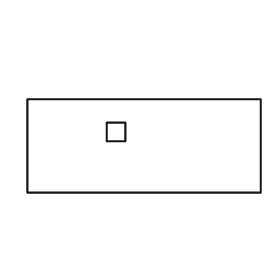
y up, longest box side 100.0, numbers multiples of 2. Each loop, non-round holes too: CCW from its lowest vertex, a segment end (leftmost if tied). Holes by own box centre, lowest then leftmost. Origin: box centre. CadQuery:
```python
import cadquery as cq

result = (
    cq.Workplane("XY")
    .moveTo(-50.0, -20.0)
    .lineTo(50.0, -20.0)
    .lineTo(50.0, 20.0)
    .lineTo(-50.0, 20.0)
    .close()
    .moveTo(-16.0, 2.0)
    .lineTo(-8.0, 2.0)
    .lineTo(-8.0, 10.0)
    .lineTo(-16.0, 10.0)
    .close()
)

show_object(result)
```